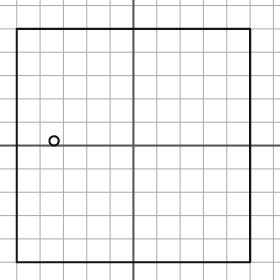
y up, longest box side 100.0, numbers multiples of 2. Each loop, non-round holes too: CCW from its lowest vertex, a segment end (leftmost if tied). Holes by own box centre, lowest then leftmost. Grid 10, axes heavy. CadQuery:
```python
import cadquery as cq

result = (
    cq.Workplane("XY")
    .moveTo(-50.0, -50.0)
    .lineTo(50.0, -50.0)
    .lineTo(50.0, 50.0)
    .lineTo(-50.0, 50.0)
    .close()
    .moveTo(-34.0, 2.0)
    .circle(2.0)
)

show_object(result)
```